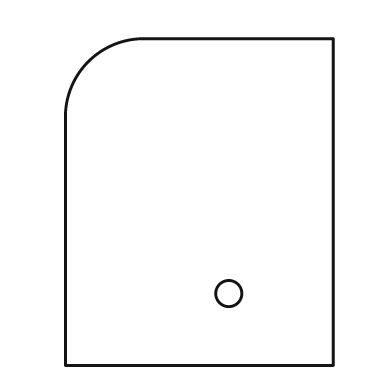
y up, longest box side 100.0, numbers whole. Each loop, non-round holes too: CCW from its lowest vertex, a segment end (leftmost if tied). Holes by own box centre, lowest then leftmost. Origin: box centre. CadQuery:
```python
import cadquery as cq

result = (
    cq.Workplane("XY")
    .moveTo(-41.0, -50.0)
    .lineTo(41.0, -50.0)
    .lineTo(41.0, 50.0)
    .lineTo(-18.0, 50.0)
    .threePointArc((-34.0, 43.0), (-41.0, 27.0))
    .close()
    .moveTo(9.0, -28.0)
    .circle(4.0)
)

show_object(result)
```